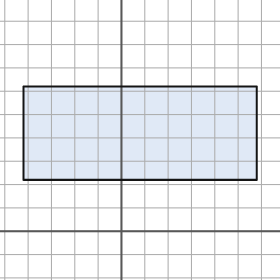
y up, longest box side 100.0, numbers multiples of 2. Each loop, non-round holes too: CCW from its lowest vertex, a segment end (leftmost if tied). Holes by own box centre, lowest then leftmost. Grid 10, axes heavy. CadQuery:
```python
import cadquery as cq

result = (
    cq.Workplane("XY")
    .moveTo(-42.0, 22.0)
    .lineTo(58.0, 22.0)
    .lineTo(58.0, 62.0)
    .lineTo(-42.0, 62.0)
    .close()
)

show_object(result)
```